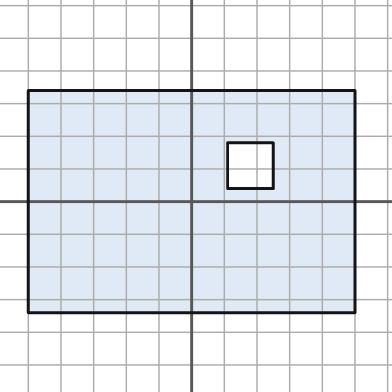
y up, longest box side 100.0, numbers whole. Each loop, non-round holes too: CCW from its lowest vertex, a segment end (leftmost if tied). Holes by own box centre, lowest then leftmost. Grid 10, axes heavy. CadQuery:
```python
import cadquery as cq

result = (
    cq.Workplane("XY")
    .moveTo(-50.0, -34.0)
    .lineTo(50.0, -34.0)
    .lineTo(50.0, 34.0)
    .lineTo(-50.0, 34.0)
    .close()
    .moveTo(11.0, 4.0)
    .lineTo(25.0, 4.0)
    .lineTo(25.0, 18.0)
    .lineTo(11.0, 18.0)
    .close()
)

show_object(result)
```